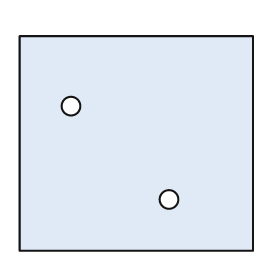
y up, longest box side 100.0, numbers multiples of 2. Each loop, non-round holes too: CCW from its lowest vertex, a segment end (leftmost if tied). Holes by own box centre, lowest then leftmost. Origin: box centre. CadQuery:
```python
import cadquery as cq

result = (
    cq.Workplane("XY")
    .moveTo(-50.0, -46.0)
    .lineTo(50.0, -46.0)
    .lineTo(50.0, 46.0)
    .lineTo(-50.0, 46.0)
    .close()
    .moveTo(14.0, -24.0)
    .circle(4.0)
    .moveTo(-28.0, 16.0)
    .circle(4.0)
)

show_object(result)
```